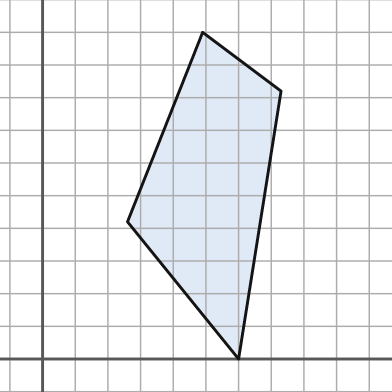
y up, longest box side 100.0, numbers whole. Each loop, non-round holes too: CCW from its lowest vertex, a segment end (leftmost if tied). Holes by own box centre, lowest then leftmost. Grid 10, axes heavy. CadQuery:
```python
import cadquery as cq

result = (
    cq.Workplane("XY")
    .moveTo(60.0, 0.0)
    .lineTo(73.0, 82.0)
    .lineTo(49.0, 100.0)
    .lineTo(26.0, 42.0)
    .close()
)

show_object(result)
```